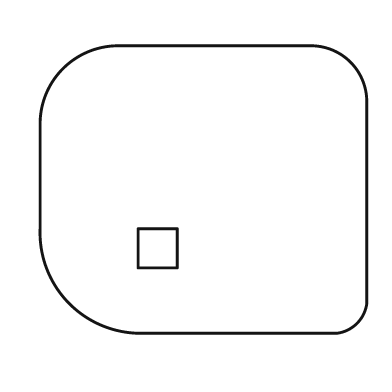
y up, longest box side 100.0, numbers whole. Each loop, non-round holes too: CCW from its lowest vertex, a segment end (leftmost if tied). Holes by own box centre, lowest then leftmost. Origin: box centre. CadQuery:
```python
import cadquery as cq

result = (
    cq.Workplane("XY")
    .moveTo(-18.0, -44.0)
    .lineTo(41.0, -44.0)
    .threePointArc((47.0, -41.0), (50.0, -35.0))
    .lineTo(50.0, 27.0)
    .threePointArc((45.0, 39.0), (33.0, 44.0))
    .lineTo(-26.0, 44.0)
    .threePointArc((-43.0, 37.0), (-50.0, 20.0))
    .lineTo(-50.0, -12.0)
    .threePointArc((-41.0, -35.0), (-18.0, -44.0))
    .close()
    .moveTo(-20.0, -24.0)
    .lineTo(-8.0, -24.0)
    .lineTo(-8.0, -12.0)
    .lineTo(-20.0, -12.0)
    .close()
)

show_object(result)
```